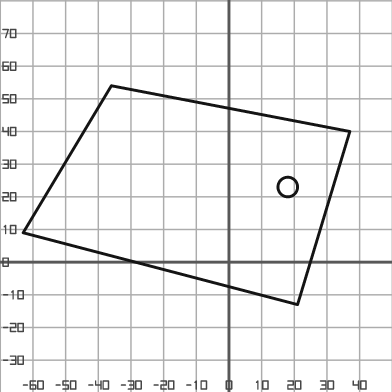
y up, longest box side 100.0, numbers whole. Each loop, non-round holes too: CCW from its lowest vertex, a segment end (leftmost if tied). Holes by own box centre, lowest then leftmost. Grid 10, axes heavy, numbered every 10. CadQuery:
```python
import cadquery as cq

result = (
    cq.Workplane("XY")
    .moveTo(21.0, -13.0)
    .lineTo(37.0, 40.0)
    .lineTo(-36.0, 54.0)
    .lineTo(-63.0, 9.0)
    .close()
    .moveTo(18.0, 23.0)
    .circle(3.0)
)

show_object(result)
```